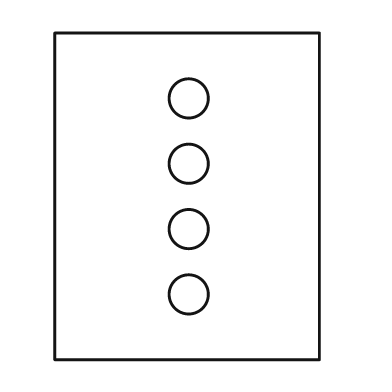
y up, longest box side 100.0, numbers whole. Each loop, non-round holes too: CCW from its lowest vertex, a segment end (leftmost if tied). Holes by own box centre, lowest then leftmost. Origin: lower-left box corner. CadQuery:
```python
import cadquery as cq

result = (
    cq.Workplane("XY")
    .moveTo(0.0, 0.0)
    .lineTo(81.0, 0.0)
    .lineTo(81.0, 100.0)
    .lineTo(0.0, 100.0)
    .close()
    .moveTo(41.0, 20.0)
    .circle(6.0)
    .moveTo(41.0, 40.0)
    .circle(6.0)
    .moveTo(41.0, 60.0)
    .circle(6.0)
    .moveTo(41.0, 80.0)
    .circle(6.0)
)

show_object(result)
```